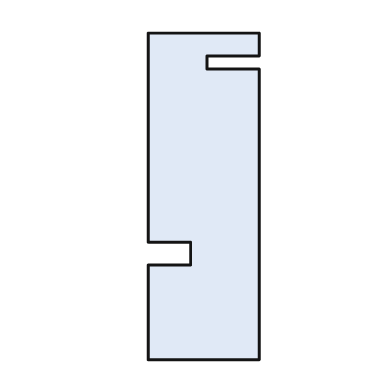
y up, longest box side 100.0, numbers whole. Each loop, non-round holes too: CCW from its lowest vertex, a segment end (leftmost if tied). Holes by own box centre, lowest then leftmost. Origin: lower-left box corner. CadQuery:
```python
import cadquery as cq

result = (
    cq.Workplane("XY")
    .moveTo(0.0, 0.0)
    .lineTo(34.0, 0.0)
    .lineTo(34.0, 89.0)
    .lineTo(18.0, 89.0)
    .lineTo(18.0, 93.0)
    .lineTo(34.0, 93.0)
    .lineTo(34.0, 100.0)
    .lineTo(0.0, 100.0)
    .lineTo(0.0, 36.0)
    .lineTo(13.0, 36.0)
    .lineTo(13.0, 29.0)
    .lineTo(0.0, 29.0)
    .close()
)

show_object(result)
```